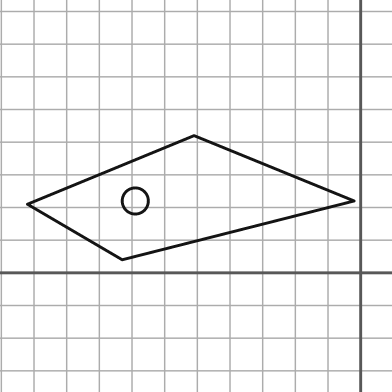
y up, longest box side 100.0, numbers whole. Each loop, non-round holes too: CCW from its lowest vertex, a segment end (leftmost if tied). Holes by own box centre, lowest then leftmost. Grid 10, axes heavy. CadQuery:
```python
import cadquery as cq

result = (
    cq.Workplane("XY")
    .moveTo(-73.0, 4.0)
    .lineTo(-2.0, 22.0)
    .lineTo(-51.0, 42.0)
    .lineTo(-102.0, 21.0)
    .close()
    .moveTo(-69.0, 22.0)
    .circle(4.0)
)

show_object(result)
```